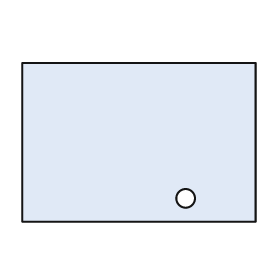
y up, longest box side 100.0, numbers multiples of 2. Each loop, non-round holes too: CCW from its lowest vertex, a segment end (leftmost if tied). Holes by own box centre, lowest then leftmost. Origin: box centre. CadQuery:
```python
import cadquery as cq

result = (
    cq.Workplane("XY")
    .moveTo(-50.0, -34.0)
    .lineTo(50.0, -34.0)
    .lineTo(50.0, 34.0)
    .lineTo(-50.0, 34.0)
    .close()
    .moveTo(20.0, -24.0)
    .circle(4.0)
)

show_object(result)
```